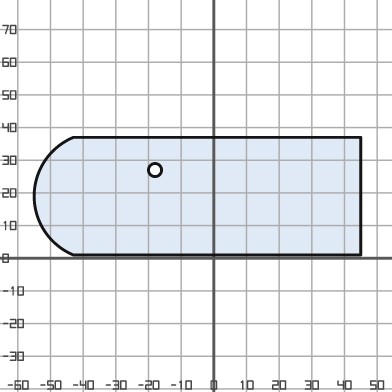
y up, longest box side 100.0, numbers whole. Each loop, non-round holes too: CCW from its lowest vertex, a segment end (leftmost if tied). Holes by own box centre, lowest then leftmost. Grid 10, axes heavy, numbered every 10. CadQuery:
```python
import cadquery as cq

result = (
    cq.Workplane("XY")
    .moveTo(-43.0, 1.0)
    .lineTo(45.0, 1.0)
    .lineTo(45.0, 37.0)
    .lineTo(-43.0, 37.0)
    .threePointArc((-55.0, 19.0), (-43.0, 1.0))
    .close()
    .moveTo(-18.0, 27.0)
    .circle(2.0)
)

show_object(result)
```